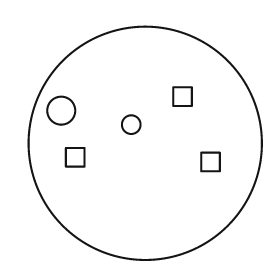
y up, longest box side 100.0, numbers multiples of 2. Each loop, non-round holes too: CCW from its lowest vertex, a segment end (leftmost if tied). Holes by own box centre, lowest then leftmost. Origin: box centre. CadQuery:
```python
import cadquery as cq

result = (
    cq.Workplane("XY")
    .moveTo(0.0, 0.0)
    .circle(50.0)
    .moveTo(24.0, -12.0)
    .lineTo(32.0, -12.0)
    .lineTo(32.0, -4.0)
    .lineTo(24.0, -4.0)
    .close()
    .moveTo(-34.0, -10.0)
    .lineTo(-26.0, -10.0)
    .lineTo(-26.0, -2.0)
    .lineTo(-34.0, -2.0)
    .close()
    .moveTo(-6.0, 8.0)
    .circle(4.0)
    .moveTo(-36.0, 14.0)
    .circle(6.0)
    .moveTo(12.0, 16.0)
    .lineTo(20.0, 16.0)
    .lineTo(20.0, 24.0)
    .lineTo(12.0, 24.0)
    .close()
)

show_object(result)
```